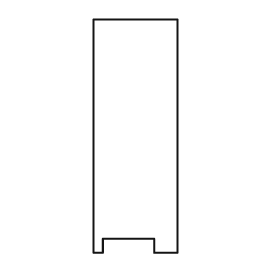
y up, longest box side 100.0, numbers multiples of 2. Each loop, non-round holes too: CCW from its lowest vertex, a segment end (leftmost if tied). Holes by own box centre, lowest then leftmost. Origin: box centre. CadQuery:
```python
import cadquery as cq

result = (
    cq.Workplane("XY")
    .moveTo(-18.0, -50.0)
    .lineTo(-14.0, -50.0)
    .lineTo(-14.0, -44.0)
    .lineTo(8.0, -44.0)
    .lineTo(8.0, -50.0)
    .lineTo(18.0, -50.0)
    .lineTo(18.0, 50.0)
    .lineTo(-18.0, 50.0)
    .close()
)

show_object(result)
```